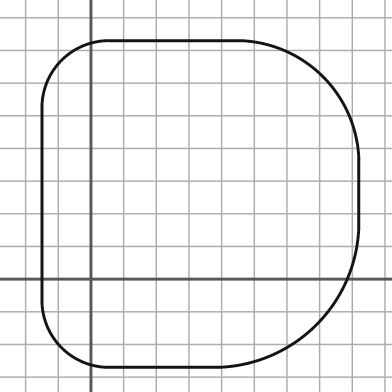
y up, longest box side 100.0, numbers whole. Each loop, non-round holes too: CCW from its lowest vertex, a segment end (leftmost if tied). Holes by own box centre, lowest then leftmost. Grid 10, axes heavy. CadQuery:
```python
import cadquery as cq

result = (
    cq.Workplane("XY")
    .moveTo(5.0, -27.0)
    .lineTo(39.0, -27.0)
    .threePointArc((69.0, -14.0), (82.0, 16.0))
    .lineTo(82.0, 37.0)
    .threePointArc((71.0, 62.0), (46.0, 73.0))
    .lineTo(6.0, 73.0)
    .threePointArc((-9.0, 67.0), (-15.0, 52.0))
    .lineTo(-15.0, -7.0)
    .threePointArc((-9.0, -21.0), (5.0, -27.0))
    .close()
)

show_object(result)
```